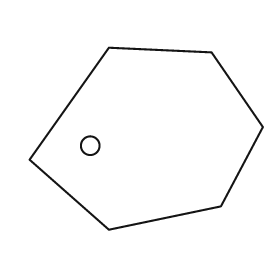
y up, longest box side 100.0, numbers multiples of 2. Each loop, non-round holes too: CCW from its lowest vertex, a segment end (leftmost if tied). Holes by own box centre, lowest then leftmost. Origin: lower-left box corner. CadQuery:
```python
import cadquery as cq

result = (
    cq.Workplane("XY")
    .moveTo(34.0, 0.0)
    .lineTo(82.0, 10.0)
    .lineTo(100.0, 44.0)
    .lineTo(78.0, 76.0)
    .lineTo(34.0, 78.0)
    .lineTo(0.0, 30.0)
    .close()
    .moveTo(26.0, 36.0)
    .circle(4.0)
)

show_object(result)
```